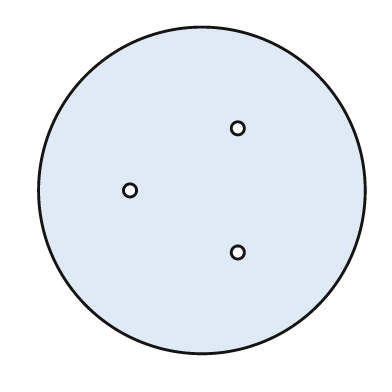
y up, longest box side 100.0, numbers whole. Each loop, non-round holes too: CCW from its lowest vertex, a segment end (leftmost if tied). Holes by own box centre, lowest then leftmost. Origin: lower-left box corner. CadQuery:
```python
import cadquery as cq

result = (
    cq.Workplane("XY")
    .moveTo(50.0, 50.0)
    .circle(50.0)
    .moveTo(61.0, 31.0)
    .circle(2.0)
    .moveTo(28.0, 50.0)
    .circle(2.0)
    .moveTo(61.0, 69.0)
    .circle(2.0)
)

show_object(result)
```